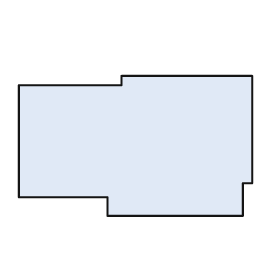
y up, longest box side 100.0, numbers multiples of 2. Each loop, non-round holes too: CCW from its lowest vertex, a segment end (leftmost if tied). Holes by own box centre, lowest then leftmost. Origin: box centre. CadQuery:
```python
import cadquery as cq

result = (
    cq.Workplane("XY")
    .moveTo(-12.0, -30.0)
    .lineTo(46.0, -30.0)
    .lineTo(46.0, -16.0)
    .lineTo(50.0, -16.0)
    .lineTo(50.0, 30.0)
    .lineTo(-6.0, 30.0)
    .lineTo(-6.0, 26.0)
    .lineTo(-50.0, 26.0)
    .lineTo(-50.0, -22.0)
    .lineTo(-12.0, -22.0)
    .close()
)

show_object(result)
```